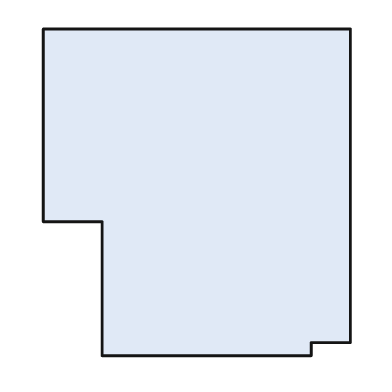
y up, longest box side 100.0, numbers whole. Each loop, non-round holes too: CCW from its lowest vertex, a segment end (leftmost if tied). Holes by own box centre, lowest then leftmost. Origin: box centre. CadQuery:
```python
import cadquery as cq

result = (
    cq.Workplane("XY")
    .moveTo(-29.0, -50.0)
    .lineTo(35.0, -50.0)
    .lineTo(35.0, -46.0)
    .lineTo(47.0, -46.0)
    .lineTo(47.0, 50.0)
    .lineTo(-47.0, 50.0)
    .lineTo(-47.0, -9.0)
    .lineTo(-29.0, -9.0)
    .close()
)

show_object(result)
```